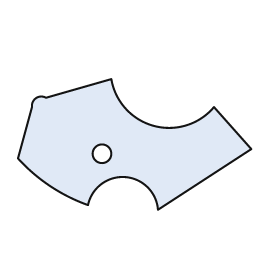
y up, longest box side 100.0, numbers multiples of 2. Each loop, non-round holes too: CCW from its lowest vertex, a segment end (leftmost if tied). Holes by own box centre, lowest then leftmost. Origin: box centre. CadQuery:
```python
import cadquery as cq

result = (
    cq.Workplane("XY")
    .moveTo(10.0, -28.0)
    .lineTo(50.0, -2.0)
    .lineTo(34.0, 16.0)
    .threePointArc((8.0, 8.0), (-10.0, 28.0))
    .lineTo(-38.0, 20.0)
    .threePointArc((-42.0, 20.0), (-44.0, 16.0))
    .lineTo(-50.0, -6.0)
    .threePointArc((-36.0, -18.0), (-20.0, -26.0))
    .threePointArc((-4.0, -14.0), (10.0, -28.0))
    .close()
    .moveTo(-14.0, -4.0)
    .circle(4.0)
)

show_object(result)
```